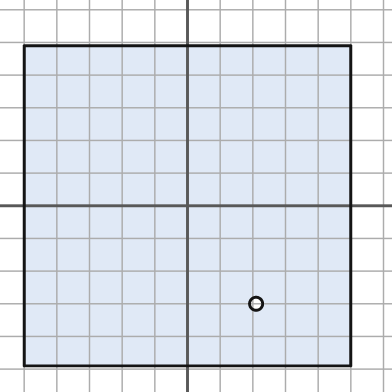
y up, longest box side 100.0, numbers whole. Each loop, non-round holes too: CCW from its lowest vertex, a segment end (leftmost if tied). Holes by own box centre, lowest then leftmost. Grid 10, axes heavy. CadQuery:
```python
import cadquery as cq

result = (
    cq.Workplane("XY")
    .moveTo(-50.0, -49.0)
    .lineTo(50.0, -49.0)
    .lineTo(50.0, 49.0)
    .lineTo(-50.0, 49.0)
    .close()
    .moveTo(21.0, -30.0)
    .circle(2.0)
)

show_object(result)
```